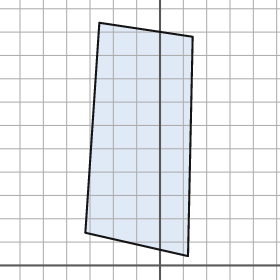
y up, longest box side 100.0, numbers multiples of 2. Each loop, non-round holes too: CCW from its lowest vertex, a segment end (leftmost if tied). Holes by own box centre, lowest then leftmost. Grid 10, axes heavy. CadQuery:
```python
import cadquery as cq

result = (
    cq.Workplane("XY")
    .moveTo(12.0, 4.0)
    .lineTo(14.0, 98.0)
    .lineTo(-26.0, 104.0)
    .lineTo(-32.0, 14.0)
    .close()
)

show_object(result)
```